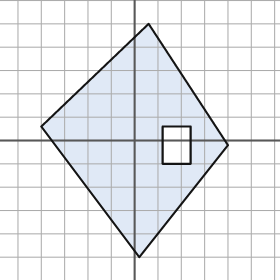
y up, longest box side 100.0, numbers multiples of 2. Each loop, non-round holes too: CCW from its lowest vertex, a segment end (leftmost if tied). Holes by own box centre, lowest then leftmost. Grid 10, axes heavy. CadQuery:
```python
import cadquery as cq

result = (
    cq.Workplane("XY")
    .moveTo(2.0, -50.0)
    .lineTo(40.0, -2.0)
    .lineTo(6.0, 50.0)
    .lineTo(-40.0, 6.0)
    .close()
    .moveTo(12.0, -10.0)
    .lineTo(24.0, -10.0)
    .lineTo(24.0, 6.0)
    .lineTo(12.0, 6.0)
    .close()
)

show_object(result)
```